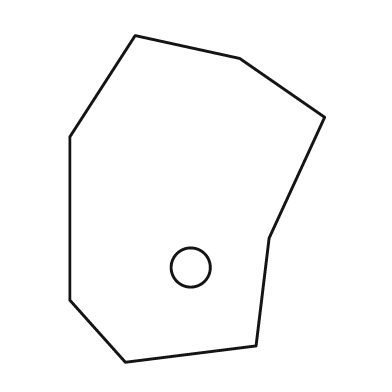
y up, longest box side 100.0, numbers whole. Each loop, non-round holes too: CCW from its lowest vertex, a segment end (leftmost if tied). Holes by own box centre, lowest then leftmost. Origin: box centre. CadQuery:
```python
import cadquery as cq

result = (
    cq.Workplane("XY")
    .moveTo(-22.0, -50.0)
    .lineTo(18.0, -45.0)
    .lineTo(22.0, -12.0)
    .lineTo(39.0, 25.0)
    .lineTo(13.0, 43.0)
    .lineTo(-19.0, 50.0)
    .lineTo(-39.0, 19.0)
    .lineTo(-39.0, -31.0)
    .close()
    .moveTo(-2.0, -21.0)
    .circle(6.0)
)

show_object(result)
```